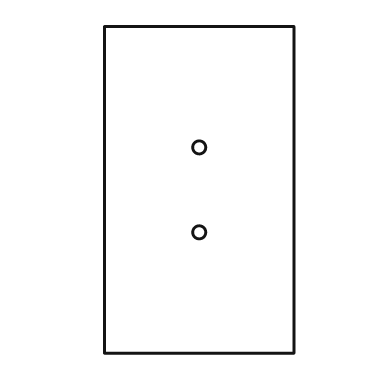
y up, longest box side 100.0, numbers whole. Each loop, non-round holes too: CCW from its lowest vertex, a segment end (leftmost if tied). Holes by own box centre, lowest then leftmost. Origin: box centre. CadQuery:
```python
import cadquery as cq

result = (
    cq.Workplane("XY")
    .moveTo(-29.0, -50.0)
    .lineTo(29.0, -50.0)
    .lineTo(29.0, 50.0)
    .lineTo(-29.0, 50.0)
    .close()
    .moveTo(0.0, -13.0)
    .circle(2.0)
    .moveTo(0.0, 13.0)
    .circle(2.0)
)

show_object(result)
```